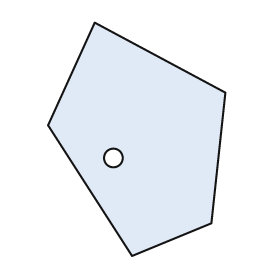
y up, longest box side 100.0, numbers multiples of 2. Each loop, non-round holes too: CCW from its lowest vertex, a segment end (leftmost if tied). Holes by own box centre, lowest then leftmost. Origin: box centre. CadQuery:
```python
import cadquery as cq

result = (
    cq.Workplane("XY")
    .moveTo(-2.0, -50.0)
    .lineTo(32.0, -36.0)
    .lineTo(38.0, 20.0)
    .lineTo(-18.0, 50.0)
    .lineTo(-38.0, 6.0)
    .close()
    .moveTo(-10.0, -8.0)
    .circle(4.0)
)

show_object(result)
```